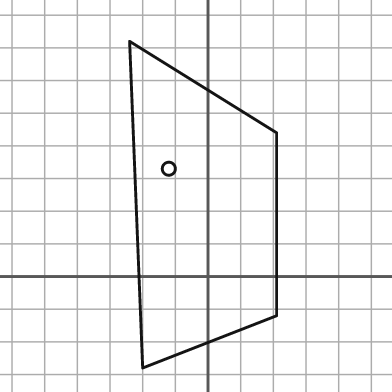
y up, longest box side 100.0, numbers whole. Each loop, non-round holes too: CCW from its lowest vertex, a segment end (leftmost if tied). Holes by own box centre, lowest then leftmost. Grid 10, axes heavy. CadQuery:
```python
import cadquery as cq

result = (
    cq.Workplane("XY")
    .moveTo(-20.0, -28.0)
    .lineTo(21.0, -12.0)
    .lineTo(21.0, 44.0)
    .lineTo(-24.0, 72.0)
    .close()
    .moveTo(-12.0, 33.0)
    .circle(2.0)
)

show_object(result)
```